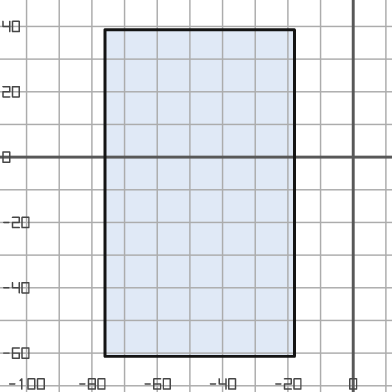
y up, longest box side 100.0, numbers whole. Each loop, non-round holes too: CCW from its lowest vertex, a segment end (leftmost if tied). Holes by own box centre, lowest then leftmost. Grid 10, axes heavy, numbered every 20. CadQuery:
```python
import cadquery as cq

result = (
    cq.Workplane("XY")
    .moveTo(-76.0, -61.0)
    .lineTo(-18.0, -61.0)
    .lineTo(-18.0, 39.0)
    .lineTo(-76.0, 39.0)
    .close()
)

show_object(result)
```